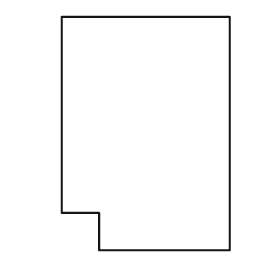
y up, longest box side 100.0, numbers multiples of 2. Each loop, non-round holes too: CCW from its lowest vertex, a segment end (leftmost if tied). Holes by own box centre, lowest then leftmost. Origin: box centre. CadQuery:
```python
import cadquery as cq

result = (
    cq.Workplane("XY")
    .moveTo(-20.0, -50.0)
    .lineTo(36.0, -50.0)
    .lineTo(36.0, 50.0)
    .lineTo(-36.0, 50.0)
    .lineTo(-36.0, -34.0)
    .lineTo(-20.0, -34.0)
    .close()
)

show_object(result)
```